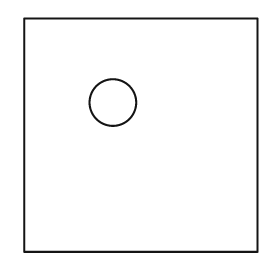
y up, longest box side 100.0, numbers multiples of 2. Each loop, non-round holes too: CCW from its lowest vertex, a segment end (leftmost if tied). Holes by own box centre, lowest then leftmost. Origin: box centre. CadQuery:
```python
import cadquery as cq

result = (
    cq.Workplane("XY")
    .moveTo(-50.0, -50.0)
    .lineTo(50.0, -50.0)
    .lineTo(50.0, 50.0)
    .lineTo(-50.0, 50.0)
    .close()
    .moveTo(-12.0, 14.0)
    .circle(10.0)
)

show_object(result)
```